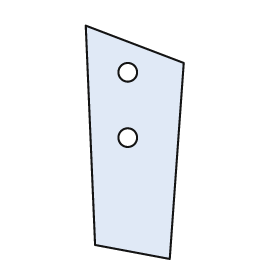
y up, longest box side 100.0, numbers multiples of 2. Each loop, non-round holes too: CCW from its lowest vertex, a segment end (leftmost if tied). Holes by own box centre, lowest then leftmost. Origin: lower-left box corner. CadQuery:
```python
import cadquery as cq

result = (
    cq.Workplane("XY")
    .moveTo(36.0, 0.0)
    .lineTo(42.0, 84.0)
    .lineTo(0.0, 100.0)
    .lineTo(4.0, 6.0)
    .close()
    .moveTo(18.0, 52.0)
    .circle(4.0)
    .moveTo(18.0, 80.0)
    .circle(4.0)
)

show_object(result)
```